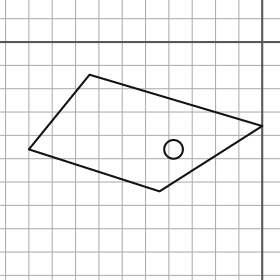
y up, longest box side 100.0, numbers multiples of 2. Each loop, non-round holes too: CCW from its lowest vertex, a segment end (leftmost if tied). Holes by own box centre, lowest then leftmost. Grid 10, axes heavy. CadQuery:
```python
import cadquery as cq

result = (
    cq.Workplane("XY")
    .moveTo(-44.0, -64.0)
    .lineTo(0.0, -36.0)
    .lineTo(-74.0, -14.0)
    .lineTo(-100.0, -46.0)
    .close()
    .moveTo(-38.0, -46.0)
    .circle(4.0)
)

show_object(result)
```